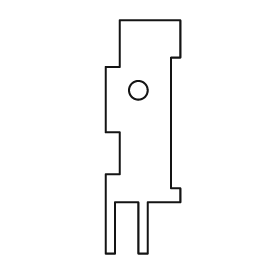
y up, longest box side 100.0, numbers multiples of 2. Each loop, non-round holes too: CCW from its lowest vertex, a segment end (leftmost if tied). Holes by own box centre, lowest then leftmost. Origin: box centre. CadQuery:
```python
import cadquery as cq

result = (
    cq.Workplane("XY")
    .moveTo(-16.0, -50.0)
    .lineTo(-12.0, -50.0)
    .lineTo(-12.0, -28.0)
    .lineTo(-2.0, -28.0)
    .lineTo(-2.0, -50.0)
    .lineTo(2.0, -50.0)
    .lineTo(2.0, -28.0)
    .lineTo(16.0, -28.0)
    .lineTo(16.0, -22.0)
    .lineTo(12.0, -22.0)
    .lineTo(12.0, 34.0)
    .lineTo(16.0, 34.0)
    .lineTo(16.0, 50.0)
    .lineTo(-10.0, 50.0)
    .lineTo(-10.0, 30.0)
    .lineTo(-16.0, 30.0)
    .lineTo(-16.0, 2.0)
    .lineTo(-10.0, 2.0)
    .lineTo(-10.0, -16.0)
    .lineTo(-16.0, -16.0)
    .close()
    .moveTo(-2.0, 20.0)
    .circle(4.0)
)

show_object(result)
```